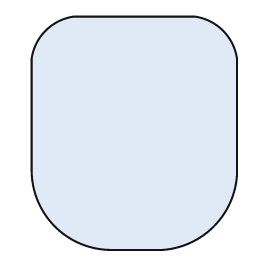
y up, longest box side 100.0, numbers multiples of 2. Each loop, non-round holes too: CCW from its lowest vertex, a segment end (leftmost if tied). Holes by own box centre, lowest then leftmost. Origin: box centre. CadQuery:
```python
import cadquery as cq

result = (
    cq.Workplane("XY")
    .moveTo(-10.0, -50.0)
    .lineTo(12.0, -50.0)
    .threePointArc((34.0, -40.0), (44.0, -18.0))
    .lineTo(44.0, 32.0)
    .threePointArc((38.0, 44.0), (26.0, 50.0))
    .lineTo(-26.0, 50.0)
    .threePointArc((-38.0, 44.0), (-44.0, 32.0))
    .lineTo(-44.0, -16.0)
    .threePointArc((-34.0, -40.0), (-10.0, -50.0))
    .close()
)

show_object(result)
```